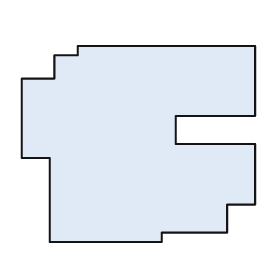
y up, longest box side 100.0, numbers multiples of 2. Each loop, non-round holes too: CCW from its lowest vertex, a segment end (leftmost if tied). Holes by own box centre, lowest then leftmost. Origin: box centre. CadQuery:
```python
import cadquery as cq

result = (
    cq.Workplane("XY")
    .moveTo(-38.0, -42.0)
    .lineTo(10.0, -42.0)
    .lineTo(10.0, -38.0)
    .lineTo(38.0, -38.0)
    .lineTo(38.0, -26.0)
    .lineTo(50.0, -26.0)
    .lineTo(50.0, 0.0)
    .lineTo(16.0, 0.0)
    .lineTo(16.0, 12.0)
    .lineTo(50.0, 12.0)
    .lineTo(50.0, 42.0)
    .lineTo(-26.0, 42.0)
    .lineTo(-26.0, 38.0)
    .lineTo(-36.0, 38.0)
    .lineTo(-36.0, 28.0)
    .lineTo(-50.0, 28.0)
    .lineTo(-50.0, -6.0)
    .lineTo(-38.0, -6.0)
    .close()
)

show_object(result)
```